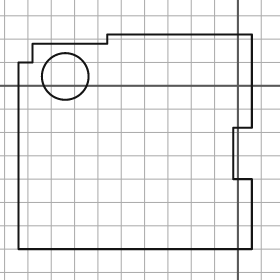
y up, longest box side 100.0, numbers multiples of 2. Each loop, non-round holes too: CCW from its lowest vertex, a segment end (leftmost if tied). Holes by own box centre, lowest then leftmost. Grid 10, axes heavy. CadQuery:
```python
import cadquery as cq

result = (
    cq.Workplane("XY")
    .moveTo(-94.0, -70.0)
    .lineTo(6.0, -70.0)
    .lineTo(6.0, -40.0)
    .lineTo(-2.0, -40.0)
    .lineTo(-2.0, -18.0)
    .lineTo(6.0, -18.0)
    .lineTo(6.0, 22.0)
    .lineTo(-56.0, 22.0)
    .lineTo(-56.0, 18.0)
    .lineTo(-88.0, 18.0)
    .lineTo(-88.0, 10.0)
    .lineTo(-94.0, 10.0)
    .close()
    .moveTo(-74.0, 4.0)
    .circle(10.0)
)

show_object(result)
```